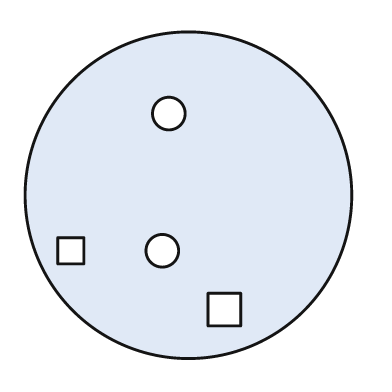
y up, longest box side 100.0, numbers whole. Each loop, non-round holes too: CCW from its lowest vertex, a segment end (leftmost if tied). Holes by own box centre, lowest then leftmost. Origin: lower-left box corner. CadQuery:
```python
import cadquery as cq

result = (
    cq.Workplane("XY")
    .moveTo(50.0, 50.0)
    .circle(50.0)
    .moveTo(56.0, 10.0)
    .lineTo(66.0, 10.0)
    .lineTo(66.0, 20.0)
    .lineTo(56.0, 20.0)
    .close()
    .moveTo(10.0, 29.0)
    .lineTo(18.0, 29.0)
    .lineTo(18.0, 37.0)
    .lineTo(10.0, 37.0)
    .close()
    .moveTo(42.0, 33.0)
    .circle(5.0)
    .moveTo(44.0, 75.0)
    .circle(5.0)
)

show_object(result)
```